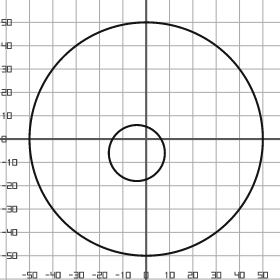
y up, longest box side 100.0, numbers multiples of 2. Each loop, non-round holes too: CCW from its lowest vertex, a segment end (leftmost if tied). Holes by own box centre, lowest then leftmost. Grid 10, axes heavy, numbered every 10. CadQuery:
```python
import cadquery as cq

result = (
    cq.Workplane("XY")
    .moveTo(0.0, 0.0)
    .circle(50.0)
    .moveTo(-4.0, -6.0)
    .circle(12.0)
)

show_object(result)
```